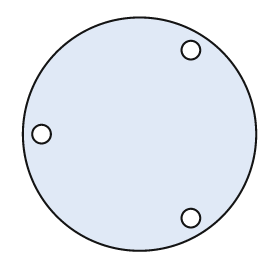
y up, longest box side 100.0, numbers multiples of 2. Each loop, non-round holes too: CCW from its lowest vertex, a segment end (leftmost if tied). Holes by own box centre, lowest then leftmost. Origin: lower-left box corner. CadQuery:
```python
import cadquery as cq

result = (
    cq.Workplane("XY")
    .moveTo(50.0, 50.0)
    .circle(50.0)
    .moveTo(72.0, 14.0)
    .circle(4.0)
    .moveTo(8.0, 50.0)
    .circle(4.0)
    .moveTo(72.0, 86.0)
    .circle(4.0)
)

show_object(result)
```